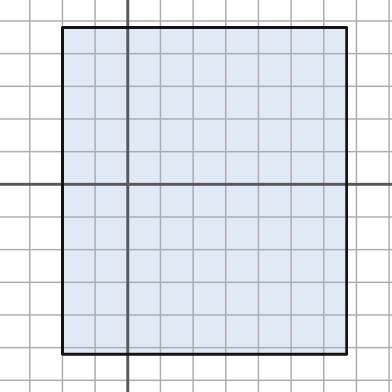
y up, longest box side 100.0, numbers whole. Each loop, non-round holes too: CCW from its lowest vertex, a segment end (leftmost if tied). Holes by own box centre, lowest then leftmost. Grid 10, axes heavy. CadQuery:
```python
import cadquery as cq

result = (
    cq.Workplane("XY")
    .moveTo(-20.0, -52.0)
    .lineTo(67.0, -52.0)
    .lineTo(67.0, 48.0)
    .lineTo(-20.0, 48.0)
    .close()
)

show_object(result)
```